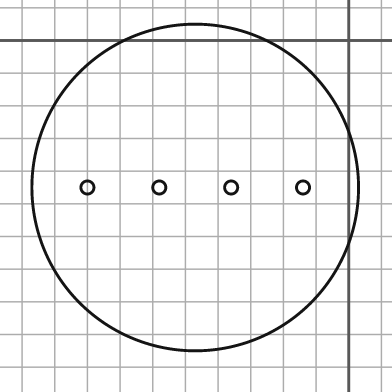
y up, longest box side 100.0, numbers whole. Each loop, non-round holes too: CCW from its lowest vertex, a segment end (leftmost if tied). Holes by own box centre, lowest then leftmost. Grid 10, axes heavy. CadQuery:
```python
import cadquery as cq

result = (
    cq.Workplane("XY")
    .moveTo(-47.0, -45.0)
    .circle(50.0)
    .moveTo(-80.0, -45.0)
    .circle(2.0)
    .moveTo(-58.0, -45.0)
    .circle(2.0)
    .moveTo(-36.0, -45.0)
    .circle(2.0)
    .moveTo(-14.0, -45.0)
    .circle(2.0)
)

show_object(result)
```